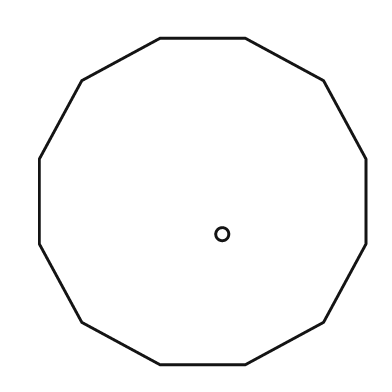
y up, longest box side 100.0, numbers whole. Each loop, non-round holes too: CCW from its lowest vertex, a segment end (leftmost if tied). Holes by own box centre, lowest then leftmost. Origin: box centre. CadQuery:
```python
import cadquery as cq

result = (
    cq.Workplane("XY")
    .moveTo(-13.0, -50.0)
    .lineTo(13.0, -50.0)
    .lineTo(37.0, -37.0)
    .lineTo(50.0, -13.0)
    .lineTo(50.0, 13.0)
    .lineTo(37.0, 37.0)
    .lineTo(13.0, 50.0)
    .lineTo(-13.0, 50.0)
    .lineTo(-37.0, 37.0)
    .lineTo(-50.0, 13.0)
    .lineTo(-50.0, -13.0)
    .lineTo(-37.0, -37.0)
    .close()
    .moveTo(6.0, -10.0)
    .circle(2.0)
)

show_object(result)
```